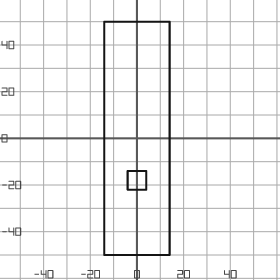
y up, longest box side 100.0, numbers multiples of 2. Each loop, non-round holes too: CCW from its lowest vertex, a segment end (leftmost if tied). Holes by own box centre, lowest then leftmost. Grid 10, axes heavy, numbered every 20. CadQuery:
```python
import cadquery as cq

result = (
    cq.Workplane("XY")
    .moveTo(-14.0, -50.0)
    .lineTo(14.0, -50.0)
    .lineTo(14.0, 50.0)
    .lineTo(-14.0, 50.0)
    .close()
    .moveTo(-4.0, -22.0)
    .lineTo(4.0, -22.0)
    .lineTo(4.0, -14.0)
    .lineTo(-4.0, -14.0)
    .close()
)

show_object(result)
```